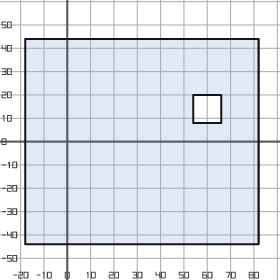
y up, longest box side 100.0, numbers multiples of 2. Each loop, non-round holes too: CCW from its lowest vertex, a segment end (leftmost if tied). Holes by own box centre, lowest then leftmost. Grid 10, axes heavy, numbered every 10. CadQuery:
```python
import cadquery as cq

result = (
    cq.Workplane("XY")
    .moveTo(-18.0, -44.0)
    .lineTo(82.0, -44.0)
    .lineTo(82.0, 44.0)
    .lineTo(-18.0, 44.0)
    .close()
    .moveTo(54.0, 8.0)
    .lineTo(66.0, 8.0)
    .lineTo(66.0, 20.0)
    .lineTo(54.0, 20.0)
    .close()
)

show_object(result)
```